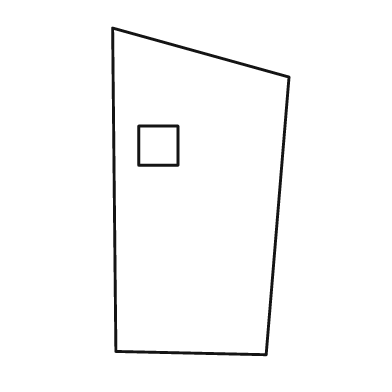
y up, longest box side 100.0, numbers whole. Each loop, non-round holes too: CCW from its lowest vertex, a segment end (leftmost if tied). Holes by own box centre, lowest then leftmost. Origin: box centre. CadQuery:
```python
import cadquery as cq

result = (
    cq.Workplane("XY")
    .moveTo(20.0, -50.0)
    .lineTo(27.0, 35.0)
    .lineTo(-27.0, 50.0)
    .lineTo(-26.0, -49.0)
    .close()
    .moveTo(-19.0, 8.0)
    .lineTo(-7.0, 8.0)
    .lineTo(-7.0, 20.0)
    .lineTo(-19.0, 20.0)
    .close()
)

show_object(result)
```